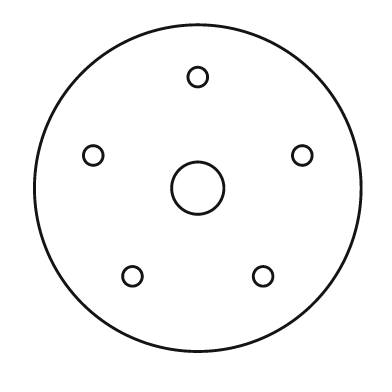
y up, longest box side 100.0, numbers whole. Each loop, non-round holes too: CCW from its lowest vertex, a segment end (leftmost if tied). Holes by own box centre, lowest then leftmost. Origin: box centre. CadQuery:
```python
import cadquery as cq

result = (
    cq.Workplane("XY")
    .moveTo(0.0, 0.0)
    .circle(50.0)
    .moveTo(-20.0, -27.0)
    .circle(3.0)
    .moveTo(20.0, -27.0)
    .circle(3.0)
    .moveTo(0.0, 0.0)
    .circle(8.0)
    .moveTo(-32.0, 10.0)
    .circle(3.0)
    .moveTo(32.0, 10.0)
    .circle(3.0)
    .moveTo(0.0, 34.0)
    .circle(3.0)
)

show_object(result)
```